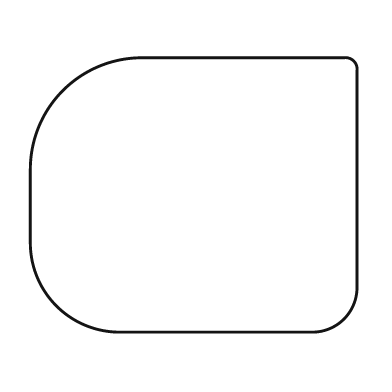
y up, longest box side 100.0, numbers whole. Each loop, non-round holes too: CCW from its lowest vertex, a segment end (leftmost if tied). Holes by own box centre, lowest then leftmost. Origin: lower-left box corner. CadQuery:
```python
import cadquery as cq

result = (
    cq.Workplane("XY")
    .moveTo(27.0, 0.0)
    .lineTo(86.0, 0.0)
    .threePointArc((96.0, 4.0), (100.0, 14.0))
    .lineTo(100.0, 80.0)
    .threePointArc((99.0, 83.0), (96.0, 84.0))
    .lineTo(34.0, 84.0)
    .threePointArc((10.0, 74.0), (0.0, 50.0))
    .lineTo(0.0, 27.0)
    .threePointArc((8.0, 8.0), (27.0, 0.0))
    .close()
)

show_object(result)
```